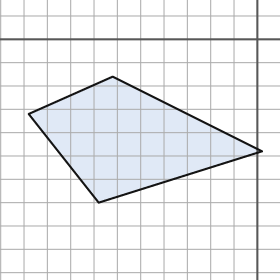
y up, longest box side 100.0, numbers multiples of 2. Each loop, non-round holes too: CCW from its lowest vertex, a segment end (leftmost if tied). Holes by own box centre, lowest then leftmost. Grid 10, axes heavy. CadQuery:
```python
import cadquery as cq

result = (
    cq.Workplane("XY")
    .moveTo(-68.0, -70.0)
    .lineTo(2.0, -48.0)
    .lineTo(-62.0, -16.0)
    .lineTo(-98.0, -32.0)
    .close()
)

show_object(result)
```